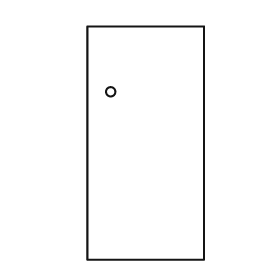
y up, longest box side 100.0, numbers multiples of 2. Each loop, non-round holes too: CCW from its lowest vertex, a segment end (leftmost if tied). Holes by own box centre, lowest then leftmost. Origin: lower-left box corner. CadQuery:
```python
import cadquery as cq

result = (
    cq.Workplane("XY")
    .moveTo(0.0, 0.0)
    .lineTo(50.0, 0.0)
    .lineTo(50.0, 100.0)
    .lineTo(0.0, 100.0)
    .close()
    .moveTo(10.0, 72.0)
    .circle(2.0)
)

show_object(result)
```